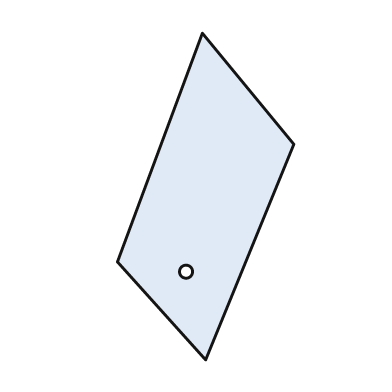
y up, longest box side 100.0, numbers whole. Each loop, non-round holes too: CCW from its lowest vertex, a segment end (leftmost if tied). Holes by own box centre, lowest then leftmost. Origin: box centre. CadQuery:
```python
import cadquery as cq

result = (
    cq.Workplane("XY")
    .moveTo(0.0, -50.0)
    .lineTo(27.0, 16.0)
    .lineTo(-1.0, 50.0)
    .lineTo(-27.0, -20.0)
    .close()
    .moveTo(-6.0, -23.0)
    .circle(2.0)
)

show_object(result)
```